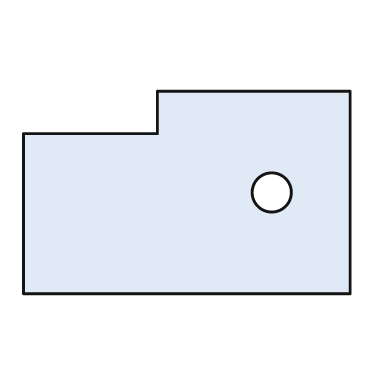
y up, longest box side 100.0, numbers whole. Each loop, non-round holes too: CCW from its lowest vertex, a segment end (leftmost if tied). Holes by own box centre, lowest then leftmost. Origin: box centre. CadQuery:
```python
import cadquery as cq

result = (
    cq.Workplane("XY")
    .moveTo(-50.0, -31.0)
    .lineTo(50.0, -31.0)
    .lineTo(50.0, 31.0)
    .lineTo(-9.0, 31.0)
    .lineTo(-9.0, 18.0)
    .lineTo(-50.0, 18.0)
    .close()
    .moveTo(26.0, 0.0)
    .circle(6.0)
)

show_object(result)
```